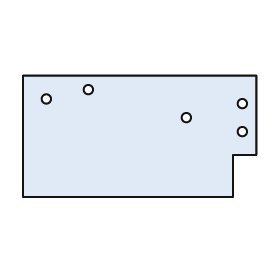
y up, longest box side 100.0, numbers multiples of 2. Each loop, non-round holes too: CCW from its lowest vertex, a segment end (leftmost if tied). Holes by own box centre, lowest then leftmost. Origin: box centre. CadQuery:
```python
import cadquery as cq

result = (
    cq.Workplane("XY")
    .moveTo(-50.0, -26.0)
    .lineTo(40.0, -26.0)
    .lineTo(40.0, -8.0)
    .lineTo(50.0, -8.0)
    .lineTo(50.0, 26.0)
    .lineTo(-50.0, 26.0)
    .close()
    .moveTo(44.0, 2.0)
    .circle(2.0)
    .moveTo(20.0, 8.0)
    .circle(2.0)
    .moveTo(44.0, 14.0)
    .circle(2.0)
    .moveTo(-40.0, 16.0)
    .circle(2.0)
    .moveTo(-22.0, 20.0)
    .circle(2.0)
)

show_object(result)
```